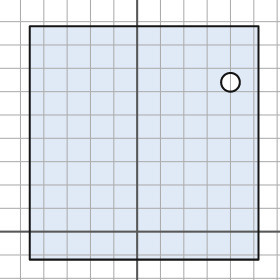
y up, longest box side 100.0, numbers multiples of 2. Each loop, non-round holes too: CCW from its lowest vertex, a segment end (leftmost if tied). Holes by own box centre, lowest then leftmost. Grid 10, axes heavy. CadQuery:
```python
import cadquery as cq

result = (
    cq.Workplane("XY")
    .moveTo(-46.0, -12.0)
    .lineTo(52.0, -12.0)
    .lineTo(52.0, 88.0)
    .lineTo(-46.0, 88.0)
    .close()
    .moveTo(40.0, 64.0)
    .circle(4.0)
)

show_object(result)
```